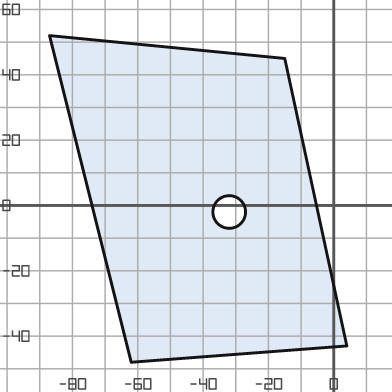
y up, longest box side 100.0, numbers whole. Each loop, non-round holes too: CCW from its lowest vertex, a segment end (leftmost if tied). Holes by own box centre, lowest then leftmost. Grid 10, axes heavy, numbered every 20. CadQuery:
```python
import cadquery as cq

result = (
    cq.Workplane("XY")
    .moveTo(-62.0, -48.0)
    .lineTo(4.0, -43.0)
    .lineTo(-15.0, 45.0)
    .lineTo(-87.0, 52.0)
    .close()
    .moveTo(-32.0, -2.0)
    .circle(5.0)
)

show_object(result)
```